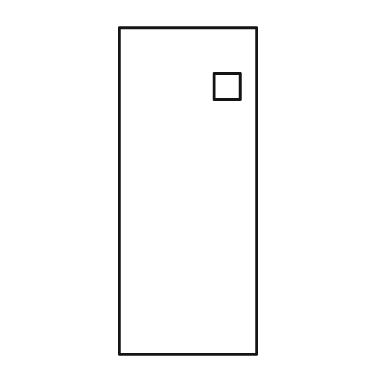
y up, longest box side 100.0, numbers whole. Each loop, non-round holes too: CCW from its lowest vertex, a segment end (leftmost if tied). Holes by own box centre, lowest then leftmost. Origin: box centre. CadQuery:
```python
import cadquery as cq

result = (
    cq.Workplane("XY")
    .moveTo(-21.0, -50.0)
    .lineTo(21.0, -50.0)
    .lineTo(21.0, 50.0)
    .lineTo(-21.0, 50.0)
    .close()
    .moveTo(8.0, 28.0)
    .lineTo(16.0, 28.0)
    .lineTo(16.0, 36.0)
    .lineTo(8.0, 36.0)
    .close()
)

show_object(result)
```